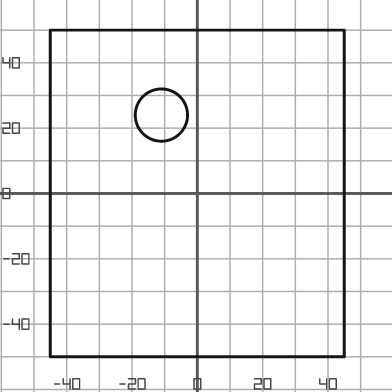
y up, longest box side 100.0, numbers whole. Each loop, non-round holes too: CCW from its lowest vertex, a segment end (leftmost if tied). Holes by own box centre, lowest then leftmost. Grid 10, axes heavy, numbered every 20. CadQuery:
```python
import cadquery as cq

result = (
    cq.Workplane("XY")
    .moveTo(-45.0, -50.0)
    .lineTo(45.0, -50.0)
    .lineTo(45.0, 50.0)
    .lineTo(-45.0, 50.0)
    .close()
    .moveTo(-11.0, 24.0)
    .circle(8.0)
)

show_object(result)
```